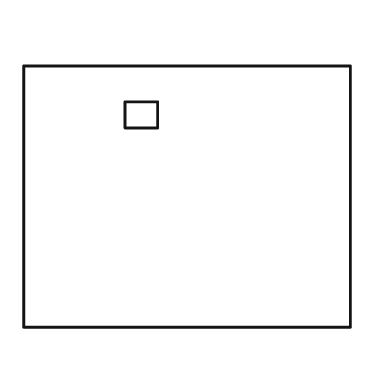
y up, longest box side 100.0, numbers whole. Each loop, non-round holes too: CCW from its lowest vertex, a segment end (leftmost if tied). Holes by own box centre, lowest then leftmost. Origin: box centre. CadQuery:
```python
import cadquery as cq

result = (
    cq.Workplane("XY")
    .moveTo(-50.0, -40.0)
    .lineTo(50.0, -40.0)
    .lineTo(50.0, 40.0)
    .lineTo(-50.0, 40.0)
    .close()
    .moveTo(-19.0, 21.0)
    .lineTo(-9.0, 21.0)
    .lineTo(-9.0, 29.0)
    .lineTo(-19.0, 29.0)
    .close()
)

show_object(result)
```